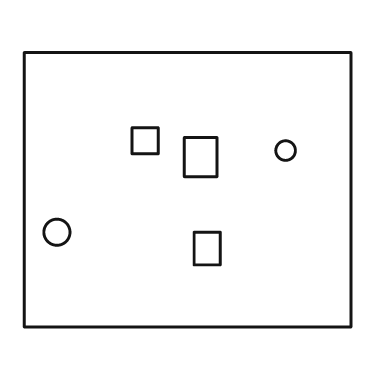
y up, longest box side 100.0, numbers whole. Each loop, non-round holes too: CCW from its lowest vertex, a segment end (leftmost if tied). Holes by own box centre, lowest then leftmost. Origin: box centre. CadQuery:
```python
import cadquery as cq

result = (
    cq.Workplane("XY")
    .moveTo(-50.0, -42.0)
    .lineTo(50.0, -42.0)
    .lineTo(50.0, 42.0)
    .lineTo(-50.0, 42.0)
    .close()
    .moveTo(2.0, -23.0)
    .lineTo(10.0, -23.0)
    .lineTo(10.0, -13.0)
    .lineTo(2.0, -13.0)
    .close()
    .moveTo(-40.0, -13.0)
    .circle(4.0)
    .moveTo(-1.0, 4.0)
    .lineTo(9.0, 4.0)
    .lineTo(9.0, 16.0)
    .lineTo(-1.0, 16.0)
    .close()
    .moveTo(30.0, 12.0)
    .circle(3.0)
    .moveTo(-17.0, 11.0)
    .lineTo(-9.0, 11.0)
    .lineTo(-9.0, 19.0)
    .lineTo(-17.0, 19.0)
    .close()
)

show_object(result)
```